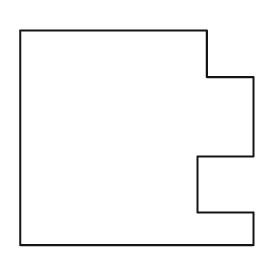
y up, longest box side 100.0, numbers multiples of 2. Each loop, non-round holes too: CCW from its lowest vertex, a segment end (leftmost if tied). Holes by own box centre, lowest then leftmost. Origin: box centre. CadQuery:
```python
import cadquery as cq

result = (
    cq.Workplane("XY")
    .moveTo(-50.0, -46.0)
    .lineTo(50.0, -46.0)
    .lineTo(50.0, -32.0)
    .lineTo(26.0, -32.0)
    .lineTo(26.0, -8.0)
    .lineTo(50.0, -8.0)
    .lineTo(50.0, 26.0)
    .lineTo(30.0, 26.0)
    .lineTo(30.0, 46.0)
    .lineTo(-50.0, 46.0)
    .close()
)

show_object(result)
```